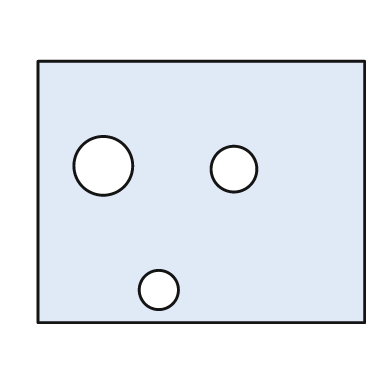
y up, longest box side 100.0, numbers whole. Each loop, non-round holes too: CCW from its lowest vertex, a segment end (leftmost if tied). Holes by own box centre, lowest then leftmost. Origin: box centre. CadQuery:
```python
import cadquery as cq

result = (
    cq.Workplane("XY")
    .moveTo(-50.0, -40.0)
    .lineTo(50.0, -40.0)
    .lineTo(50.0, 40.0)
    .lineTo(-50.0, 40.0)
    .close()
    .moveTo(-13.0, -30.0)
    .circle(6.0)
    .moveTo(10.0, 7.0)
    .circle(7.0)
    .moveTo(-30.0, 8.0)
    .circle(9.0)
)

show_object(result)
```